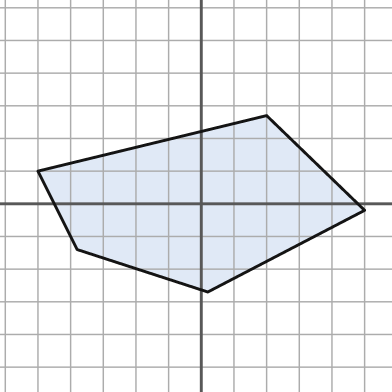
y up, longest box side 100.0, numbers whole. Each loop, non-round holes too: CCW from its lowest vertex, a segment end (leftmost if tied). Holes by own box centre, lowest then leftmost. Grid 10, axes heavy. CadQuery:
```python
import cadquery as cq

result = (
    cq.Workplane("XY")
    .moveTo(2.0, -27.0)
    .lineTo(50.0, -2.0)
    .lineTo(20.0, 27.0)
    .lineTo(-50.0, 10.0)
    .lineTo(-38.0, -14.0)
    .close()
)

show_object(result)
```